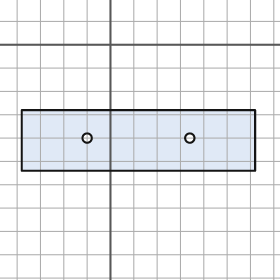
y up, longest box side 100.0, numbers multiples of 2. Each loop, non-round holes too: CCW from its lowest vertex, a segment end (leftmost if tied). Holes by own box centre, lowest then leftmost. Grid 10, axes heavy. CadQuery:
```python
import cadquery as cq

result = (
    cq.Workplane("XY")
    .moveTo(-38.0, -54.0)
    .lineTo(62.0, -54.0)
    .lineTo(62.0, -28.0)
    .lineTo(-38.0, -28.0)
    .close()
    .moveTo(-10.0, -40.0)
    .circle(2.0)
    .moveTo(34.0, -40.0)
    .circle(2.0)
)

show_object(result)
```